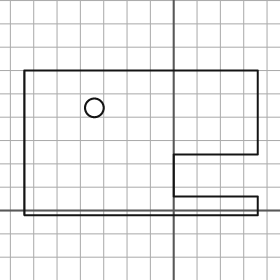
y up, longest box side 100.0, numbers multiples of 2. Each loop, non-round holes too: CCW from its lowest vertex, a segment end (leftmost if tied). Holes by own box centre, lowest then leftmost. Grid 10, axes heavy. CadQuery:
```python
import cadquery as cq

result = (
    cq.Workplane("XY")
    .moveTo(-64.0, -2.0)
    .lineTo(36.0, -2.0)
    .lineTo(36.0, 6.0)
    .lineTo(0.0, 6.0)
    .lineTo(0.0, 24.0)
    .lineTo(36.0, 24.0)
    .lineTo(36.0, 60.0)
    .lineTo(-64.0, 60.0)
    .close()
    .moveTo(-34.0, 44.0)
    .circle(4.0)
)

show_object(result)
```